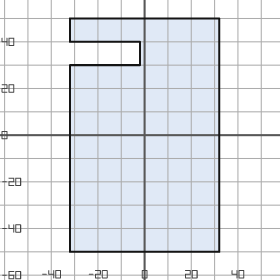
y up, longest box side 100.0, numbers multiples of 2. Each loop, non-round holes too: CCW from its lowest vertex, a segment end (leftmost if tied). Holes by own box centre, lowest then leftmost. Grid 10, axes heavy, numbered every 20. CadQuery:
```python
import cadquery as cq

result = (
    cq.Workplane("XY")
    .moveTo(-32.0, -50.0)
    .lineTo(32.0, -50.0)
    .lineTo(32.0, 50.0)
    .lineTo(-32.0, 50.0)
    .lineTo(-32.0, 40.0)
    .lineTo(-2.0, 40.0)
    .lineTo(-2.0, 30.0)
    .lineTo(-32.0, 30.0)
    .close()
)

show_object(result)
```